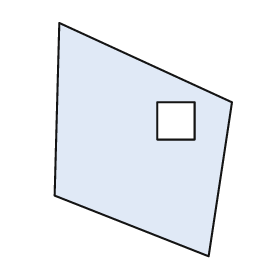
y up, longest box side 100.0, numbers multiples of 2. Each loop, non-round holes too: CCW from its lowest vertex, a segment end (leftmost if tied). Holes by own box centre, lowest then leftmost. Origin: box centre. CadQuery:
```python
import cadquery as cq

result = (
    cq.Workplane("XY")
    .moveTo(28.0, -50.0)
    .lineTo(38.0, 16.0)
    .lineTo(-36.0, 50.0)
    .lineTo(-38.0, -24.0)
    .close()
    .moveTo(6.0, 0.0)
    .lineTo(22.0, 0.0)
    .lineTo(22.0, 16.0)
    .lineTo(6.0, 16.0)
    .close()
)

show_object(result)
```